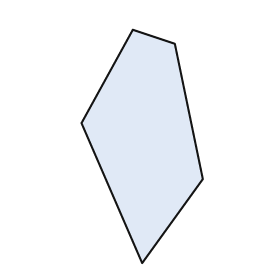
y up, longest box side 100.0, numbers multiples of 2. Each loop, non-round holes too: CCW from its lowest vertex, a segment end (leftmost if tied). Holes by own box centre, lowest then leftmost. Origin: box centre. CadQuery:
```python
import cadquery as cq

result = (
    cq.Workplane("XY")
    .moveTo(0.0, -50.0)
    .lineTo(26.0, -14.0)
    .lineTo(14.0, 44.0)
    .lineTo(-4.0, 50.0)
    .lineTo(-26.0, 10.0)
    .close()
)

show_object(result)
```